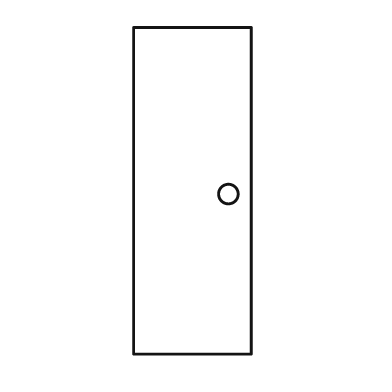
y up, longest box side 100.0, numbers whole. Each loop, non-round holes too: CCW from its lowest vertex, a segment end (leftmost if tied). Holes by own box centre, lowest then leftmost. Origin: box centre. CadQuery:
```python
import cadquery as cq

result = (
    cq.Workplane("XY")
    .moveTo(-18.0, -50.0)
    .lineTo(18.0, -50.0)
    .lineTo(18.0, 50.0)
    .lineTo(-18.0, 50.0)
    .close()
    .moveTo(11.0, -1.0)
    .circle(3.0)
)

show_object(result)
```